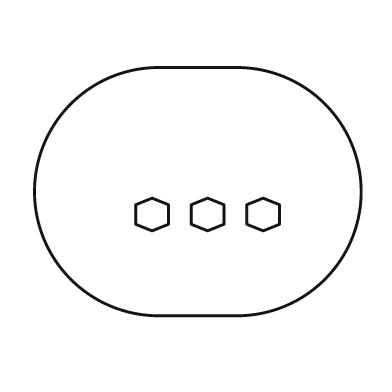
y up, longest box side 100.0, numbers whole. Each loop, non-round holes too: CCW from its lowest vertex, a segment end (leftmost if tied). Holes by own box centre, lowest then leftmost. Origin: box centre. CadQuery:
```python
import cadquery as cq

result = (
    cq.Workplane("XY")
    .moveTo(-12.0, -38.0)
    .lineTo(12.0, -38.0)
    .threePointArc((50.0, 0.0), (12.0, 38.0))
    .lineTo(-12.0, 38.0)
    .threePointArc((-50.0, 0.0), (-12.0, -38.0))
    .close()
    .moveTo(-14.0, -12.0)
    .lineTo(-9.0, -10.0)
    .lineTo(-9.0, -4.0)
    .lineTo(-14.0, -2.0)
    .lineTo(-19.0, -4.0)
    .lineTo(-19.0, -10.0)
    .close()
    .moveTo(3.0, -12.0)
    .lineTo(8.0, -10.0)
    .lineTo(8.0, -4.0)
    .lineTo(3.0, -2.0)
    .lineTo(-2.0, -4.0)
    .lineTo(-2.0, -10.0)
    .close()
    .moveTo(20.0, -12.0)
    .lineTo(25.0, -10.0)
    .lineTo(25.0, -4.0)
    .lineTo(20.0, -2.0)
    .lineTo(15.0, -4.0)
    .lineTo(15.0, -10.0)
    .close()
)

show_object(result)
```